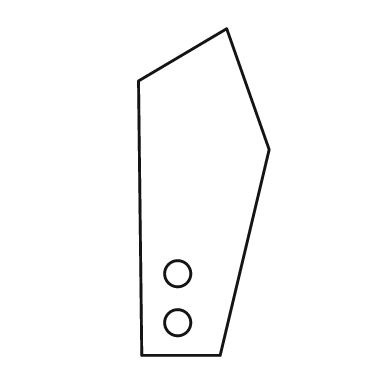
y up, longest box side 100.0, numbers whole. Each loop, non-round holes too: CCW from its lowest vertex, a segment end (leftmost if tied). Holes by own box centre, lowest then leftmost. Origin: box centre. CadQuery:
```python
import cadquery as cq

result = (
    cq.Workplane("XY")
    .moveTo(-19.0, -50.0)
    .lineTo(5.0, -50.0)
    .lineTo(20.0, 13.0)
    .lineTo(7.0, 50.0)
    .lineTo(-20.0, 34.0)
    .close()
    .moveTo(-8.0, -40.0)
    .circle(4.0)
    .moveTo(-8.0, -25.0)
    .circle(4.0)
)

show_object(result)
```